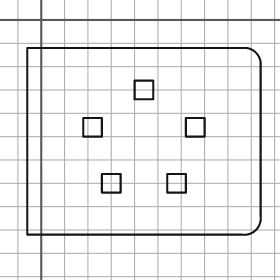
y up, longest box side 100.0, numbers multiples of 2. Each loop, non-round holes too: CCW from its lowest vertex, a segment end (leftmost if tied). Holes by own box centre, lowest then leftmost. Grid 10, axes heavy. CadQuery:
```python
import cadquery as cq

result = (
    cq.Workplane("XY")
    .moveTo(-6.0, -92.0)
    .lineTo(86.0, -92.0)
    .threePointArc((92.0, -90.0), (94.0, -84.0))
    .lineTo(94.0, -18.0)
    .threePointArc((92.0, -14.0), (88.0, -12.0))
    .lineTo(-6.0, -12.0)
    .close()
    .moveTo(26.0, -74.0)
    .lineTo(34.0, -74.0)
    .lineTo(34.0, -66.0)
    .lineTo(26.0, -66.0)
    .close()
    .moveTo(54.0, -74.0)
    .lineTo(62.0, -74.0)
    .lineTo(62.0, -66.0)
    .lineTo(54.0, -66.0)
    .close()
    .moveTo(18.0, -50.0)
    .lineTo(26.0, -50.0)
    .lineTo(26.0, -42.0)
    .lineTo(18.0, -42.0)
    .close()
    .moveTo(62.0, -50.0)
    .lineTo(70.0, -50.0)
    .lineTo(70.0, -42.0)
    .lineTo(62.0, -42.0)
    .close()
    .moveTo(40.0, -34.0)
    .lineTo(48.0, -34.0)
    .lineTo(48.0, -26.0)
    .lineTo(40.0, -26.0)
    .close()
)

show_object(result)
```